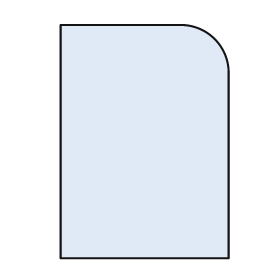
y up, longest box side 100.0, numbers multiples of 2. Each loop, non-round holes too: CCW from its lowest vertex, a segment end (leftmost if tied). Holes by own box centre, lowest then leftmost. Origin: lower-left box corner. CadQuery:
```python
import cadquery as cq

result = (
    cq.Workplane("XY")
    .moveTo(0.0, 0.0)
    .lineTo(72.0, 0.0)
    .lineTo(72.0, 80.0)
    .threePointArc((66.0, 94.0), (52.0, 100.0))
    .lineTo(0.0, 100.0)
    .close()
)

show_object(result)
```